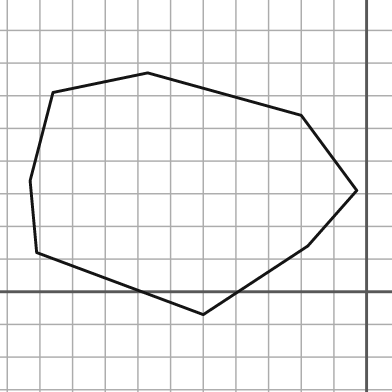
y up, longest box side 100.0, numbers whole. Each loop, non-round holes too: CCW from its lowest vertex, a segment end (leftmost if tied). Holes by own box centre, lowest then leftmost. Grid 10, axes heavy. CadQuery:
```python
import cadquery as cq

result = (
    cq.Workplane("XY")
    .moveTo(-50.0, -7.0)
    .lineTo(-18.0, 14.0)
    .lineTo(-3.0, 31.0)
    .lineTo(-20.0, 54.0)
    .lineTo(-67.0, 67.0)
    .lineTo(-96.0, 61.0)
    .lineTo(-103.0, 34.0)
    .lineTo(-101.0, 12.0)
    .close()
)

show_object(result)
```